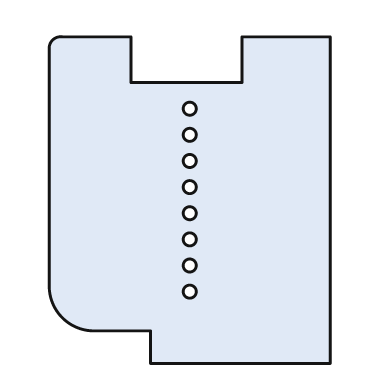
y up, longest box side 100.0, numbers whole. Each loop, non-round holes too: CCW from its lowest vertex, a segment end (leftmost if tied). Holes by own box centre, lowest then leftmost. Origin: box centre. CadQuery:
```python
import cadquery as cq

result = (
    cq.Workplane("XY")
    .moveTo(-12.0, -50.0)
    .lineTo(43.0, -50.0)
    .lineTo(43.0, 50.0)
    .lineTo(16.0, 50.0)
    .lineTo(16.0, 36.0)
    .lineTo(-18.0, 36.0)
    .lineTo(-18.0, 50.0)
    .lineTo(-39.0, 50.0)
    .threePointArc((-42.0, 49.0), (-43.0, 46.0))
    .lineTo(-43.0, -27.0)
    .threePointArc((-39.0, -36.0), (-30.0, -40.0))
    .lineTo(-12.0, -40.0)
    .close()
    .moveTo(0.0, -28.0)
    .circle(2.0)
    .moveTo(0.0, -20.0)
    .circle(2.0)
    .moveTo(0.0, -12.0)
    .circle(2.0)
    .moveTo(0.0, -4.0)
    .circle(2.0)
    .moveTo(0.0, 4.0)
    .circle(2.0)
    .moveTo(0.0, 12.0)
    .circle(2.0)
    .moveTo(0.0, 20.0)
    .circle(2.0)
    .moveTo(0.0, 28.0)
    .circle(2.0)
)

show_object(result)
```